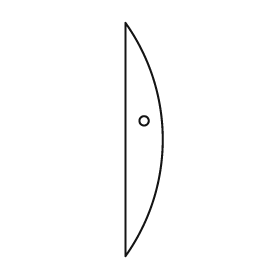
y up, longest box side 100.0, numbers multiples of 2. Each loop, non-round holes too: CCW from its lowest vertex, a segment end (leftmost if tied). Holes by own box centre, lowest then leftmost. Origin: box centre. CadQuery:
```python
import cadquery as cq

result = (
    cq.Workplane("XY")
    .moveTo(-8.0, -50.0)
    .threePointArc((8.0, 0.0), (-8.0, 50.0))
    .close()
    .moveTo(0.0, 8.0)
    .circle(2.0)
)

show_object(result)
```